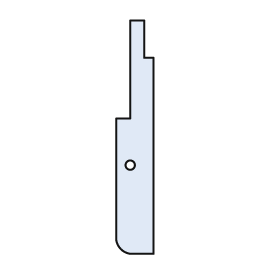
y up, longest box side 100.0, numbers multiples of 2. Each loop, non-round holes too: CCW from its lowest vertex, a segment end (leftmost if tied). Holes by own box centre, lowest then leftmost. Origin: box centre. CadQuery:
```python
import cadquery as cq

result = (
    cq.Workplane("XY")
    .moveTo(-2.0, -50.0)
    .lineTo(8.0, -50.0)
    .lineTo(8.0, 34.0)
    .lineTo(4.0, 34.0)
    .lineTo(4.0, 50.0)
    .lineTo(-2.0, 50.0)
    .lineTo(-2.0, 8.0)
    .lineTo(-8.0, 8.0)
    .lineTo(-8.0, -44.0)
    .threePointArc((-6.0, -48.0), (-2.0, -50.0))
    .close()
    .moveTo(-2.0, -12.0)
    .circle(2.0)
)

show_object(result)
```